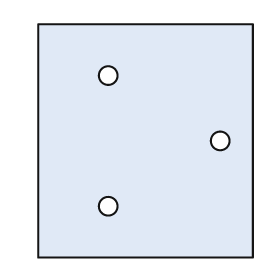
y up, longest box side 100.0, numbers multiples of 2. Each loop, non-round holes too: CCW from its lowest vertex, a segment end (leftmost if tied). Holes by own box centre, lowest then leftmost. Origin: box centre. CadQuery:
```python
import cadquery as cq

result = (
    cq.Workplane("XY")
    .moveTo(-46.0, -50.0)
    .lineTo(46.0, -50.0)
    .lineTo(46.0, 50.0)
    .lineTo(-46.0, 50.0)
    .close()
    .moveTo(-16.0, -28.0)
    .circle(4.0)
    .moveTo(32.0, 0.0)
    .circle(4.0)
    .moveTo(-16.0, 28.0)
    .circle(4.0)
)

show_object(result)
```